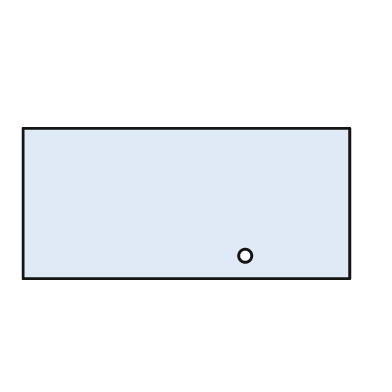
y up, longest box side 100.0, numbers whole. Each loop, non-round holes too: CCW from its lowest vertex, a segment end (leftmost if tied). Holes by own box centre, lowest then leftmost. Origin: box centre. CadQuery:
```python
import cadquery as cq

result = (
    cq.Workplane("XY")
    .moveTo(-50.0, -23.0)
    .lineTo(50.0, -23.0)
    .lineTo(50.0, 23.0)
    .lineTo(-50.0, 23.0)
    .close()
    .moveTo(18.0, -16.0)
    .circle(2.0)
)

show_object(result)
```